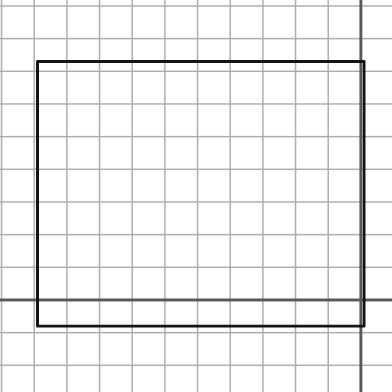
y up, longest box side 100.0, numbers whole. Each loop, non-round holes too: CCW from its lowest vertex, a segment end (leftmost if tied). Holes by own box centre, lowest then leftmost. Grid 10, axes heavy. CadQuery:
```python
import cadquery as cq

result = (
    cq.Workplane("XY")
    .moveTo(-99.0, -8.0)
    .lineTo(1.0, -8.0)
    .lineTo(1.0, 73.0)
    .lineTo(-99.0, 73.0)
    .close()
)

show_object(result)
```